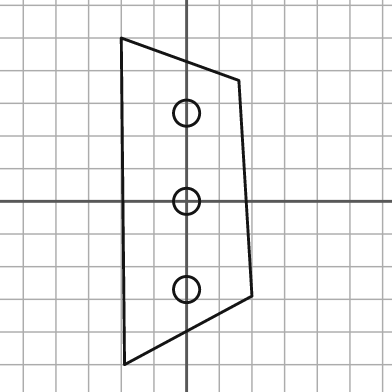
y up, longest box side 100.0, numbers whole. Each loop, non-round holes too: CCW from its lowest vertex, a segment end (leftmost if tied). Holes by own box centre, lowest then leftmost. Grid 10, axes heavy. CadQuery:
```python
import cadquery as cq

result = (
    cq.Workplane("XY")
    .moveTo(-19.0, -50.0)
    .lineTo(20.0, -29.0)
    .lineTo(16.0, 37.0)
    .lineTo(-20.0, 50.0)
    .close()
    .moveTo(0.0, -27.0)
    .circle(4.0)
    .moveTo(0.0, 0.0)
    .circle(4.0)
    .moveTo(0.0, 27.0)
    .circle(4.0)
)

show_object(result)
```